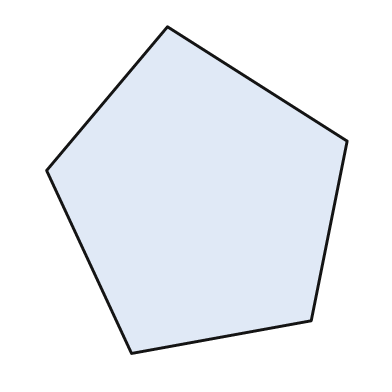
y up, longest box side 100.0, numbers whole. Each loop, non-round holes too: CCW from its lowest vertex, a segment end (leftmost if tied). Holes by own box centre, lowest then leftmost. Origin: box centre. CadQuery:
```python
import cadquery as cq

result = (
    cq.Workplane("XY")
    .moveTo(-20.0, -50.0)
    .lineTo(35.0, -40.0)
    .lineTo(46.0, 15.0)
    .lineTo(-9.0, 50.0)
    .lineTo(-46.0, 6.0)
    .close()
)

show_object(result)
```